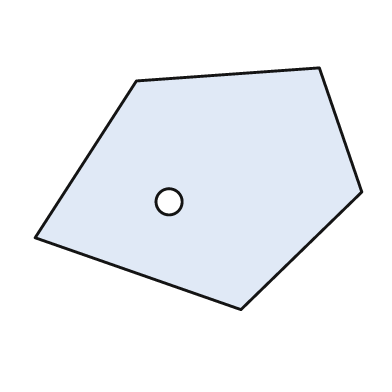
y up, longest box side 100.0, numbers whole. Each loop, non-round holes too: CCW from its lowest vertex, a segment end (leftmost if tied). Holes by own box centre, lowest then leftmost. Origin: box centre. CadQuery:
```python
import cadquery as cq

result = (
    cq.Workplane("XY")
    .moveTo(13.0, -37.0)
    .lineTo(50.0, -1.0)
    .lineTo(37.0, 37.0)
    .lineTo(-19.0, 33.0)
    .lineTo(-50.0, -15.0)
    .close()
    .moveTo(-9.0, -4.0)
    .circle(4.0)
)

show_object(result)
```